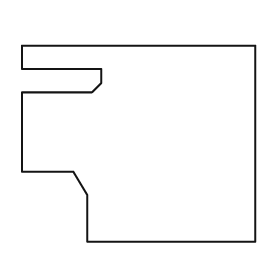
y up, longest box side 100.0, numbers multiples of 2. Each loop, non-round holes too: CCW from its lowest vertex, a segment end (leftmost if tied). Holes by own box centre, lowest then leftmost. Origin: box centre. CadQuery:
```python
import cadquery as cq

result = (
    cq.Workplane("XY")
    .moveTo(-22.0, -42.0)
    .lineTo(50.0, -42.0)
    .lineTo(50.0, 42.0)
    .lineTo(-50.0, 42.0)
    .lineTo(-50.0, 32.0)
    .lineTo(-16.0, 32.0)
    .lineTo(-16.0, 26.0)
    .lineTo(-20.0, 22.0)
    .lineTo(-50.0, 22.0)
    .lineTo(-50.0, -12.0)
    .lineTo(-28.0, -12.0)
    .lineTo(-22.0, -22.0)
    .close()
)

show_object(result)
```